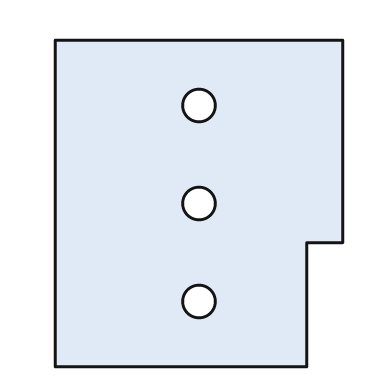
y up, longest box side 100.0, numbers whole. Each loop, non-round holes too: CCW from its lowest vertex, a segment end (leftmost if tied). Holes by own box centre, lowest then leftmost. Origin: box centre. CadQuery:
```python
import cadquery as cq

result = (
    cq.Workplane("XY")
    .moveTo(-44.0, -50.0)
    .lineTo(33.0, -50.0)
    .lineTo(33.0, -12.0)
    .lineTo(44.0, -12.0)
    .lineTo(44.0, 50.0)
    .lineTo(-44.0, 50.0)
    .close()
    .moveTo(0.0, -30.0)
    .circle(5.0)
    .moveTo(0.0, 0.0)
    .circle(5.0)
    .moveTo(0.0, 30.0)
    .circle(5.0)
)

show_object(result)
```